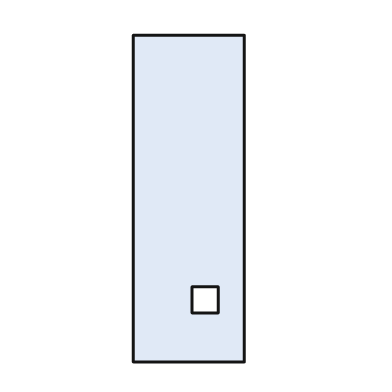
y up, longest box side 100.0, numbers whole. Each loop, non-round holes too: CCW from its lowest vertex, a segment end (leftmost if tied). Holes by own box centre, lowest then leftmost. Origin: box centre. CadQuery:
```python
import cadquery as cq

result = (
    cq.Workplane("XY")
    .moveTo(-17.0, -50.0)
    .lineTo(17.0, -50.0)
    .lineTo(17.0, 50.0)
    .lineTo(-17.0, 50.0)
    .close()
    .moveTo(1.0, -35.0)
    .lineTo(9.0, -35.0)
    .lineTo(9.0, -27.0)
    .lineTo(1.0, -27.0)
    .close()
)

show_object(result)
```